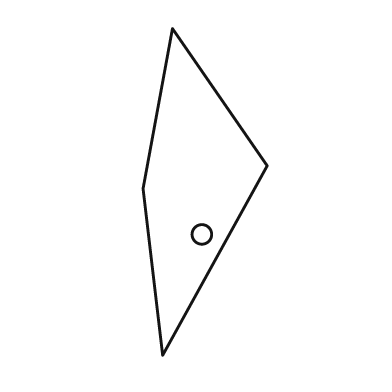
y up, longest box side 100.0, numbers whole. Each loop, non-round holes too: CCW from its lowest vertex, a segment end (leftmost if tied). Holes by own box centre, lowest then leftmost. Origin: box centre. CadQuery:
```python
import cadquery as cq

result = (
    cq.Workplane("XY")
    .moveTo(-13.0, -50.0)
    .lineTo(19.0, 8.0)
    .lineTo(-10.0, 50.0)
    .lineTo(-19.0, 1.0)
    .close()
    .moveTo(-1.0, -13.0)
    .circle(3.0)
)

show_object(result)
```